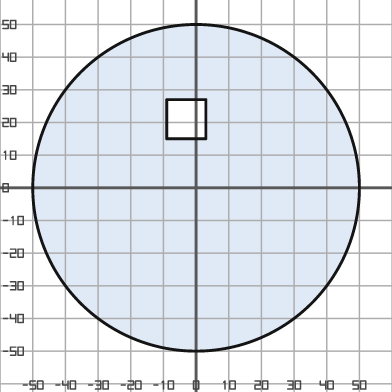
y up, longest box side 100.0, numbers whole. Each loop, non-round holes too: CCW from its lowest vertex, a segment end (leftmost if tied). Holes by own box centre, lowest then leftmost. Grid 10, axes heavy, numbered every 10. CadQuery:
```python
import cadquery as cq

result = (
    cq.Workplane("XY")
    .moveTo(0.0, 0.0)
    .circle(50.0)
    .moveTo(-9.0, 15.0)
    .lineTo(3.0, 15.0)
    .lineTo(3.0, 27.0)
    .lineTo(-9.0, 27.0)
    .close()
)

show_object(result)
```